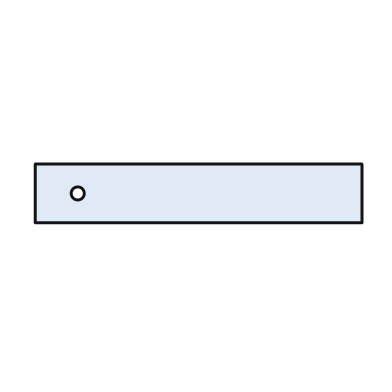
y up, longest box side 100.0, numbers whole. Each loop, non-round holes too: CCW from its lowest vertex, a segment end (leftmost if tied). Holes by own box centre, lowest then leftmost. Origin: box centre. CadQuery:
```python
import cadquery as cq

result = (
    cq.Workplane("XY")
    .moveTo(-50.0, -9.0)
    .lineTo(50.0, -9.0)
    .lineTo(50.0, 9.0)
    .lineTo(-50.0, 9.0)
    .close()
    .moveTo(-37.0, 0.0)
    .circle(2.0)
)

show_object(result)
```